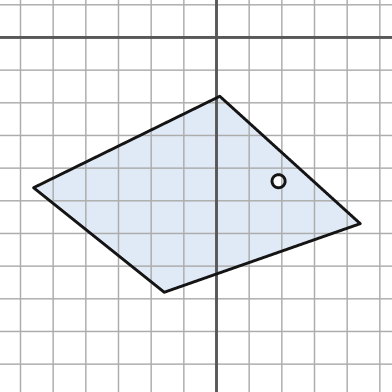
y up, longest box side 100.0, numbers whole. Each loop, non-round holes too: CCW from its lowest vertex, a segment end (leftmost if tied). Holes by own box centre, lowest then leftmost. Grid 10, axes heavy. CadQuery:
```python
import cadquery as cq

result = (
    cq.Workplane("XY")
    .moveTo(-16.0, -78.0)
    .lineTo(44.0, -57.0)
    .lineTo(1.0, -18.0)
    .lineTo(-56.0, -46.0)
    .close()
    .moveTo(19.0, -44.0)
    .circle(2.0)
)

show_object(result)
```